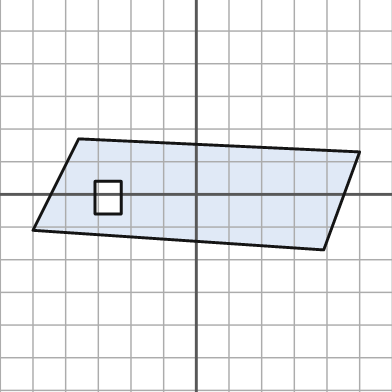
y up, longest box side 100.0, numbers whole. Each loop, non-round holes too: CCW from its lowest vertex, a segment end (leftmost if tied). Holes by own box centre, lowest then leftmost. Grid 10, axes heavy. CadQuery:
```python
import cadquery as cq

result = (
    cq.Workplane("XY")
    .moveTo(39.0, -17.0)
    .lineTo(50.0, 13.0)
    .lineTo(-36.0, 17.0)
    .lineTo(-50.0, -11.0)
    .close()
    .moveTo(-31.0, -6.0)
    .lineTo(-23.0, -6.0)
    .lineTo(-23.0, 4.0)
    .lineTo(-31.0, 4.0)
    .close()
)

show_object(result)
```